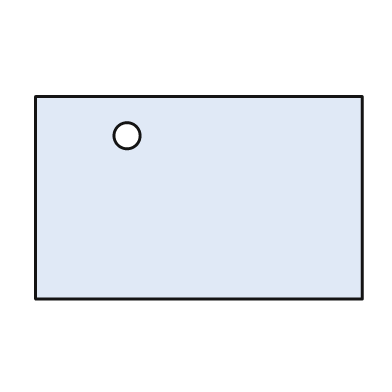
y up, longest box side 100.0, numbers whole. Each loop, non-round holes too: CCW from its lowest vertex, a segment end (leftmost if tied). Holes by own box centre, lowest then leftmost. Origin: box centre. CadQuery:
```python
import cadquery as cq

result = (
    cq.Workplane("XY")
    .moveTo(-50.0, -31.0)
    .lineTo(50.0, -31.0)
    .lineTo(50.0, 31.0)
    .lineTo(-50.0, 31.0)
    .close()
    .moveTo(-22.0, 19.0)
    .circle(4.0)
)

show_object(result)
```